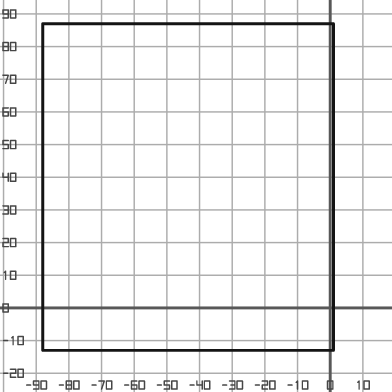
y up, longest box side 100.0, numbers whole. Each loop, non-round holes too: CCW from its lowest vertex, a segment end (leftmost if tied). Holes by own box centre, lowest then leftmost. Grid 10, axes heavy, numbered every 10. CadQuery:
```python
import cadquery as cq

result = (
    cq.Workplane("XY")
    .moveTo(-88.0, -13.0)
    .lineTo(1.0, -13.0)
    .lineTo(1.0, 87.0)
    .lineTo(-88.0, 87.0)
    .close()
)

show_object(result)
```